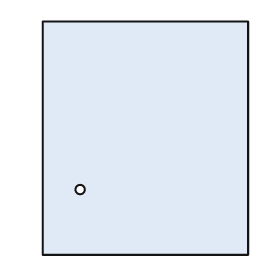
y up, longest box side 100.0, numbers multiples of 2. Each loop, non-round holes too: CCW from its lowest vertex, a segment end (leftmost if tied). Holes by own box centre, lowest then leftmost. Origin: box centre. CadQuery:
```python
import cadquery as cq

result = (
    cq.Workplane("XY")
    .moveTo(-44.0, -50.0)
    .lineTo(44.0, -50.0)
    .lineTo(44.0, 50.0)
    .lineTo(-44.0, 50.0)
    .close()
    .moveTo(-28.0, -22.0)
    .circle(2.0)
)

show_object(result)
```